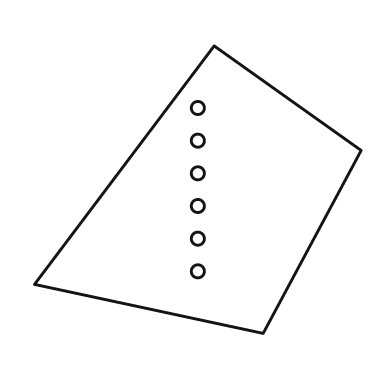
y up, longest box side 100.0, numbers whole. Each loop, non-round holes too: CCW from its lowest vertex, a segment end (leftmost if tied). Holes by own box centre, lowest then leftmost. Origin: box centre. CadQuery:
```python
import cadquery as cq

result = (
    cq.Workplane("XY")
    .moveTo(20.0, -44.0)
    .lineTo(50.0, 12.0)
    .lineTo(5.0, 44.0)
    .lineTo(-50.0, -29.0)
    .close()
    .moveTo(0.0, -25.0)
    .circle(2.0)
    .moveTo(0.0, -15.0)
    .circle(2.0)
    .moveTo(0.0, -5.0)
    .circle(2.0)
    .moveTo(0.0, 5.0)
    .circle(2.0)
    .moveTo(0.0, 15.0)
    .circle(2.0)
    .moveTo(0.0, 25.0)
    .circle(2.0)
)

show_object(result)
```